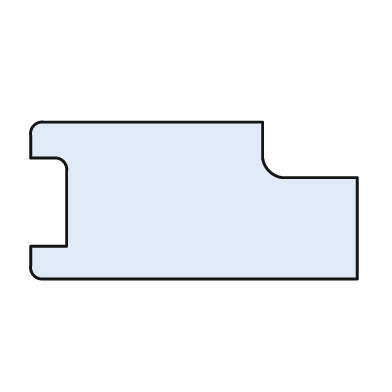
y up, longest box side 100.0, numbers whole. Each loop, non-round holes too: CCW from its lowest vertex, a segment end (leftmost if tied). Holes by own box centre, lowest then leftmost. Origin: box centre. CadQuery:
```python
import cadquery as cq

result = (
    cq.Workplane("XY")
    .moveTo(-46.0, -24.0)
    .lineTo(50.0, -24.0)
    .lineTo(50.0, 7.0)
    .lineTo(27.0, 7.0)
    .threePointArc((23.0, 9.0), (21.0, 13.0))
    .lineTo(21.0, 24.0)
    .lineTo(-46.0, 24.0)
    .threePointArc((-49.0, 23.0), (-50.0, 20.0))
    .lineTo(-50.0, 13.0)
    .lineTo(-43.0, 13.0)
    .threePointArc((-40.0, 12.0), (-39.0, 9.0))
    .lineTo(-39.0, -14.0)
    .lineTo(-50.0, -14.0)
    .lineTo(-50.0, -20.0)
    .threePointArc((-49.0, -23.0), (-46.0, -24.0))
    .close()
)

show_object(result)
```